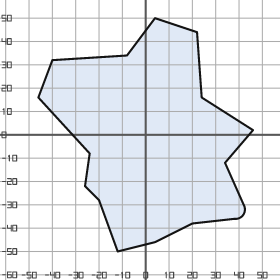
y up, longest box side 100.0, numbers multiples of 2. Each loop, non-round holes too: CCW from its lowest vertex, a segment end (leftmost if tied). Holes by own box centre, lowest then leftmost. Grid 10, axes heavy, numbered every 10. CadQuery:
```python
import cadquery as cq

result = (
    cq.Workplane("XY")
    .moveTo(-12.0, -50.0)
    .lineTo(4.0, -46.0)
    .lineTo(20.0, -38.0)
    .lineTo(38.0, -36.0)
    .threePointArc((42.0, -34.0), (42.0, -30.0))
    .lineTo(34.0, -12.0)
    .lineTo(46.0, 2.0)
    .lineTo(24.0, 16.0)
    .lineTo(22.0, 44.0)
    .lineTo(4.0, 50.0)
    .lineTo(-8.0, 34.0)
    .lineTo(-40.0, 32.0)
    .lineTo(-46.0, 16.0)
    .lineTo(-24.0, -8.0)
    .lineTo(-26.0, -22.0)
    .lineTo(-20.0, -28.0)
    .close()
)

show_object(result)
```